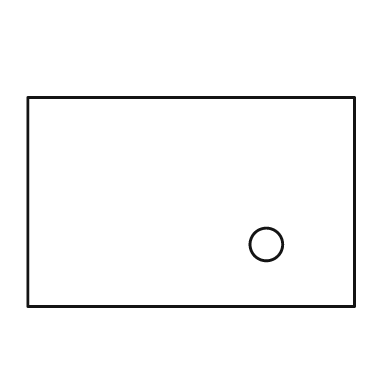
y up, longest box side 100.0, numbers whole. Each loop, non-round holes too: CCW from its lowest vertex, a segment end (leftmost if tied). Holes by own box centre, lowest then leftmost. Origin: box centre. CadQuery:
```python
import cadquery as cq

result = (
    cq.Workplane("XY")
    .moveTo(-50.0, -32.0)
    .lineTo(50.0, -32.0)
    .lineTo(50.0, 32.0)
    .lineTo(-50.0, 32.0)
    .close()
    .moveTo(23.0, -13.0)
    .circle(5.0)
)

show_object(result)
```